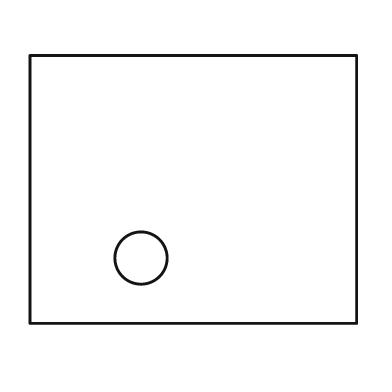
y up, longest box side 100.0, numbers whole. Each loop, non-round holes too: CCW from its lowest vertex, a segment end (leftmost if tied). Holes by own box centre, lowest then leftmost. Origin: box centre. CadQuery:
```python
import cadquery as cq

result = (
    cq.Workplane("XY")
    .moveTo(-50.0, -41.0)
    .lineTo(50.0, -41.0)
    .lineTo(50.0, 41.0)
    .lineTo(-50.0, 41.0)
    .close()
    .moveTo(-16.0, -21.0)
    .circle(8.0)
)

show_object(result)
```